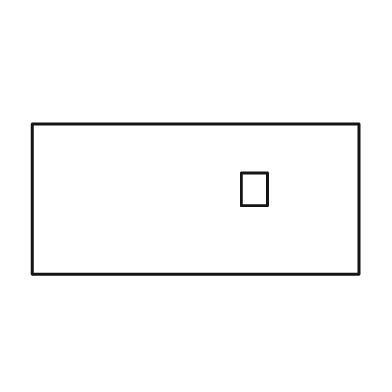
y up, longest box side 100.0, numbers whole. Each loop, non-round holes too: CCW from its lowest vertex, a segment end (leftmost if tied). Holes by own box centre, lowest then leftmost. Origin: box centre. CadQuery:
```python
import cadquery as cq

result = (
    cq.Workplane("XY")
    .moveTo(-50.0, -23.0)
    .lineTo(50.0, -23.0)
    .lineTo(50.0, 23.0)
    .lineTo(-50.0, 23.0)
    .close()
    .moveTo(14.0, -2.0)
    .lineTo(22.0, -2.0)
    .lineTo(22.0, 8.0)
    .lineTo(14.0, 8.0)
    .close()
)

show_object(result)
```